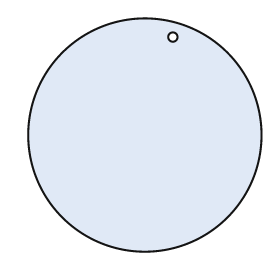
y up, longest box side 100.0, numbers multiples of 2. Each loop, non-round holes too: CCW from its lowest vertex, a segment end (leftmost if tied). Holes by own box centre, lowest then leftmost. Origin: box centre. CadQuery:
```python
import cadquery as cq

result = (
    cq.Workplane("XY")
    .moveTo(0.0, 0.0)
    .circle(50.0)
    .moveTo(12.0, 42.0)
    .circle(2.0)
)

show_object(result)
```